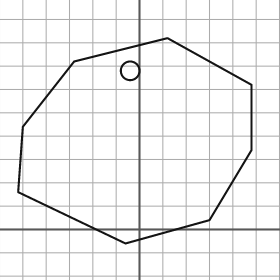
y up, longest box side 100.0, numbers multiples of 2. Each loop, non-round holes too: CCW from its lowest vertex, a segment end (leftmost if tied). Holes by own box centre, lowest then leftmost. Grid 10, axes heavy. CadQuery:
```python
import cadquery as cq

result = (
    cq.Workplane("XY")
    .moveTo(-6.0, -6.0)
    .lineTo(30.0, 4.0)
    .lineTo(48.0, 34.0)
    .lineTo(48.0, 62.0)
    .lineTo(12.0, 82.0)
    .lineTo(-28.0, 72.0)
    .lineTo(-50.0, 44.0)
    .lineTo(-52.0, 16.0)
    .close()
    .moveTo(-4.0, 68.0)
    .circle(4.0)
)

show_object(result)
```